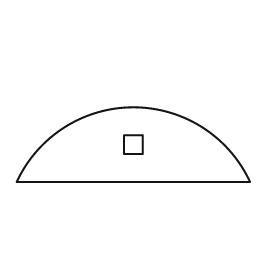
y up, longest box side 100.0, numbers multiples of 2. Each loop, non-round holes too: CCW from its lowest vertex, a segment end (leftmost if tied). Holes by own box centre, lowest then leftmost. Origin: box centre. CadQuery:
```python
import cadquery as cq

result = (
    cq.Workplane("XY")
    .moveTo(-50.0, -16.0)
    .lineTo(50.0, -16.0)
    .threePointArc((0.0, 16.0), (-50.0, -16.0))
    .close()
    .moveTo(-4.0, -4.0)
    .lineTo(4.0, -4.0)
    .lineTo(4.0, 4.0)
    .lineTo(-4.0, 4.0)
    .close()
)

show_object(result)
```